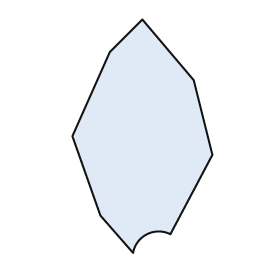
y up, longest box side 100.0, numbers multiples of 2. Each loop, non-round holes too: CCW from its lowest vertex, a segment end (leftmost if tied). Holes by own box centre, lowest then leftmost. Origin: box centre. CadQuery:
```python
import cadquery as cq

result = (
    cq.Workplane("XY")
    .moveTo(-4.0, -50.0)
    .threePointArc((2.0, -42.0), (12.0, -42.0))
    .lineTo(30.0, -8.0)
    .lineTo(22.0, 24.0)
    .lineTo(0.0, 50.0)
    .lineTo(-14.0, 36.0)
    .lineTo(-30.0, 0.0)
    .lineTo(-18.0, -34.0)
    .close()
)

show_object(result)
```